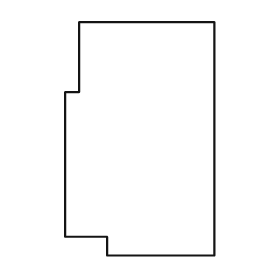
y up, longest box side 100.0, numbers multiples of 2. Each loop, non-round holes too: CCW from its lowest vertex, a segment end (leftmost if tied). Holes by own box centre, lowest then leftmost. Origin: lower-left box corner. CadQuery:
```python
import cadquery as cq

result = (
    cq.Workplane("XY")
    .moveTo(18.0, 0.0)
    .lineTo(64.0, 0.0)
    .lineTo(64.0, 100.0)
    .lineTo(6.0, 100.0)
    .lineTo(6.0, 70.0)
    .lineTo(0.0, 70.0)
    .lineTo(0.0, 8.0)
    .lineTo(18.0, 8.0)
    .close()
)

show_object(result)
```